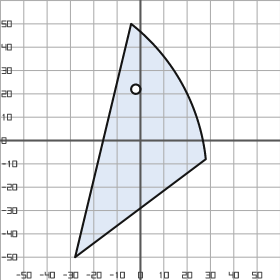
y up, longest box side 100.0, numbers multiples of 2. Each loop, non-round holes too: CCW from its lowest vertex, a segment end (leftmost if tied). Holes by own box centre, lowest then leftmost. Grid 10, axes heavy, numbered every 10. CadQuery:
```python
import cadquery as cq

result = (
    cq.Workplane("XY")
    .moveTo(-28.0, -50.0)
    .lineTo(28.0, -8.0)
    .threePointArc((18.0, 24.0), (-4.0, 50.0))
    .close()
    .moveTo(-2.0, 22.0)
    .circle(2.0)
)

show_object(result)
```